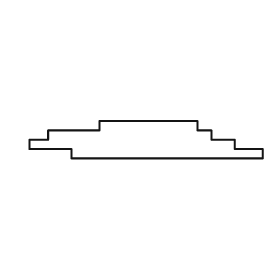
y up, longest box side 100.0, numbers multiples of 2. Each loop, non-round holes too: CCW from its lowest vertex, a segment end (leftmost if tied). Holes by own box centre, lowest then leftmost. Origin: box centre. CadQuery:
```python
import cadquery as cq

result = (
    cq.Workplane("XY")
    .moveTo(-32.0, -8.0)
    .lineTo(50.0, -8.0)
    .lineTo(50.0, -4.0)
    .lineTo(38.0, -4.0)
    .lineTo(38.0, 0.0)
    .lineTo(28.0, 0.0)
    .lineTo(28.0, 4.0)
    .lineTo(22.0, 4.0)
    .lineTo(22.0, 8.0)
    .lineTo(-20.0, 8.0)
    .lineTo(-20.0, 4.0)
    .lineTo(-42.0, 4.0)
    .lineTo(-42.0, 0.0)
    .lineTo(-50.0, 0.0)
    .lineTo(-50.0, -4.0)
    .lineTo(-32.0, -4.0)
    .close()
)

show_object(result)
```